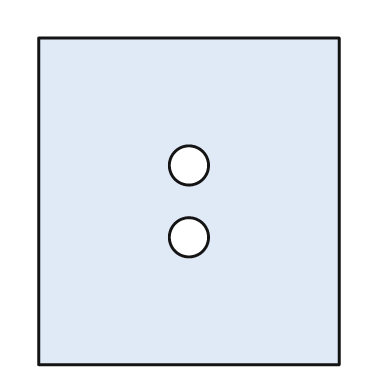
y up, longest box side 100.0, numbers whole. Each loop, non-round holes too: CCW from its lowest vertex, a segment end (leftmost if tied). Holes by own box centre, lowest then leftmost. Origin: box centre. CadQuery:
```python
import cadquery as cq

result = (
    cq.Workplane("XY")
    .moveTo(-46.0, -50.0)
    .lineTo(46.0, -50.0)
    .lineTo(46.0, 50.0)
    .lineTo(-46.0, 50.0)
    .close()
    .moveTo(0.0, -11.0)
    .circle(6.0)
    .moveTo(0.0, 11.0)
    .circle(6.0)
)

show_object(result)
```